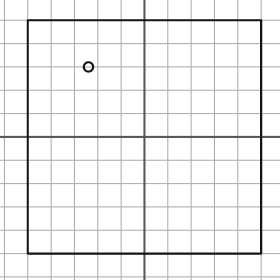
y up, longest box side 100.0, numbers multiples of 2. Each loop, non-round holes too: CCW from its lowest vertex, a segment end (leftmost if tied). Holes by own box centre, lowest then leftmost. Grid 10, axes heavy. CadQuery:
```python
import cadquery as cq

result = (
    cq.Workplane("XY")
    .moveTo(-50.0, -50.0)
    .lineTo(50.0, -50.0)
    .lineTo(50.0, 50.0)
    .lineTo(-50.0, 50.0)
    .close()
    .moveTo(-24.0, 30.0)
    .circle(2.0)
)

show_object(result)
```